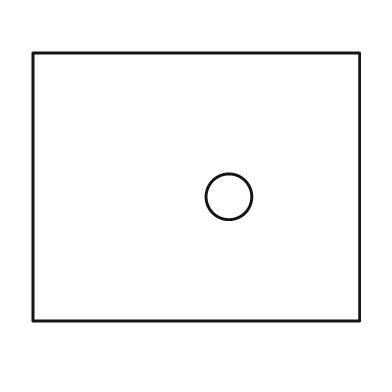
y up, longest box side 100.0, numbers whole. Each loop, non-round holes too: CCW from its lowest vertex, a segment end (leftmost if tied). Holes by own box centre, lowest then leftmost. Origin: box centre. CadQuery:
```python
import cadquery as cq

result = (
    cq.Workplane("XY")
    .moveTo(-50.0, -41.0)
    .lineTo(50.0, -41.0)
    .lineTo(50.0, 41.0)
    .lineTo(-50.0, 41.0)
    .close()
    .moveTo(10.0, -3.0)
    .circle(7.0)
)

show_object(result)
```